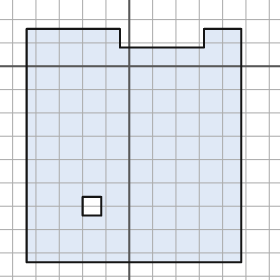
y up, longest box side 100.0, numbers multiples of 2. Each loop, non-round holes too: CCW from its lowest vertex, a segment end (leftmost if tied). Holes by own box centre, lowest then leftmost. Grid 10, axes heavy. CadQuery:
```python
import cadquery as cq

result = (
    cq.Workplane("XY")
    .moveTo(-44.0, -84.0)
    .lineTo(48.0, -84.0)
    .lineTo(48.0, 16.0)
    .lineTo(32.0, 16.0)
    .lineTo(32.0, 8.0)
    .lineTo(-4.0, 8.0)
    .lineTo(-4.0, 16.0)
    .lineTo(-44.0, 16.0)
    .close()
    .moveTo(-20.0, -64.0)
    .lineTo(-12.0, -64.0)
    .lineTo(-12.0, -56.0)
    .lineTo(-20.0, -56.0)
    .close()
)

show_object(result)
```